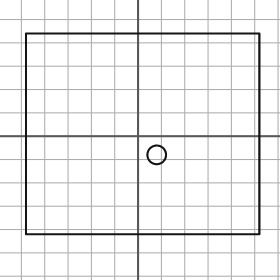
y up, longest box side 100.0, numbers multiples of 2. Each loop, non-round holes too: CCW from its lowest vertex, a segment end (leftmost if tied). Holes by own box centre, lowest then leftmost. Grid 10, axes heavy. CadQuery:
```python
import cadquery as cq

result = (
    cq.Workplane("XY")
    .moveTo(-48.0, -42.0)
    .lineTo(52.0, -42.0)
    .lineTo(52.0, 44.0)
    .lineTo(-48.0, 44.0)
    .close()
    .moveTo(8.0, -8.0)
    .circle(4.0)
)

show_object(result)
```